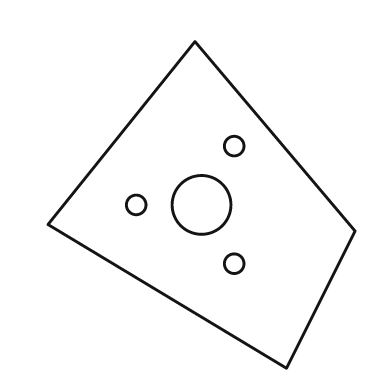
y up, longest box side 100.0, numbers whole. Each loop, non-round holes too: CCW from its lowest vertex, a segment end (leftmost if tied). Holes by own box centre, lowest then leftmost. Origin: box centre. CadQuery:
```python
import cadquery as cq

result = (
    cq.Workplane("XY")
    .moveTo(26.0, -50.0)
    .lineTo(47.0, -8.0)
    .lineTo(-2.0, 50.0)
    .lineTo(-47.0, -6.0)
    .close()
    .moveTo(10.0, -18.0)
    .circle(3.0)
    .moveTo(-20.0, 0.0)
    .circle(3.0)
    .moveTo(0.0, 0.0)
    .circle(9.0)
    .moveTo(10.0, 18.0)
    .circle(3.0)
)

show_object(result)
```